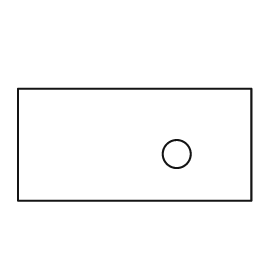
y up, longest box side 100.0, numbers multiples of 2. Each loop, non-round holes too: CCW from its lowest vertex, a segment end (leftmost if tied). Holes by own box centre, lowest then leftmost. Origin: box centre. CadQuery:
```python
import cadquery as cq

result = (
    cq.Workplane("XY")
    .moveTo(-50.0, -24.0)
    .lineTo(50.0, -24.0)
    .lineTo(50.0, 24.0)
    .lineTo(-50.0, 24.0)
    .close()
    .moveTo(18.0, -4.0)
    .circle(6.0)
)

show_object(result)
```